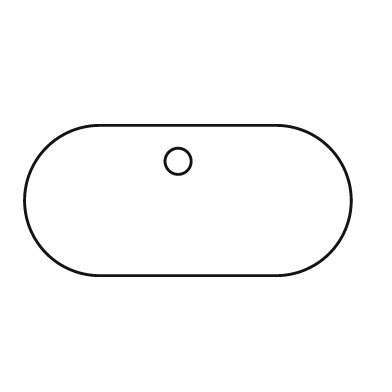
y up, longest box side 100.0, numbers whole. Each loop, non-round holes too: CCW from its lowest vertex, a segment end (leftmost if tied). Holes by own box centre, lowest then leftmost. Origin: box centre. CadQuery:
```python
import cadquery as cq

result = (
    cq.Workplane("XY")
    .moveTo(-27.0, -23.0)
    .lineTo(27.0, -23.0)
    .threePointArc((50.0, 0.0), (27.0, 23.0))
    .lineTo(-27.0, 23.0)
    .threePointArc((-50.0, 0.0), (-27.0, -23.0))
    .close()
    .moveTo(-3.0, 12.0)
    .circle(4.0)
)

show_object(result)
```